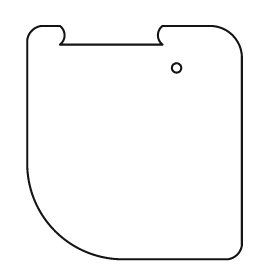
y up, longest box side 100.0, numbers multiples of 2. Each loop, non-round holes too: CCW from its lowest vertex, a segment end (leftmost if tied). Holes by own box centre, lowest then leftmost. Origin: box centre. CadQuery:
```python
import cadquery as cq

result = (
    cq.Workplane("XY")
    .moveTo(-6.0, -50.0)
    .lineTo(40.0, -50.0)
    .threePointArc((44.0, -48.0), (46.0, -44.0))
    .lineTo(46.0, 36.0)
    .threePointArc((42.0, 46.0), (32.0, 50.0))
    .lineTo(12.0, 50.0)
    .threePointArc((10.0, 46.0), (12.0, 42.0))
    .lineTo(-32.0, 42.0)
    .threePointArc((-30.0, 46.0), (-32.0, 50.0))
    .lineTo(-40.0, 50.0)
    .threePointArc((-44.0, 48.0), (-46.0, 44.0))
    .lineTo(-46.0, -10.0)
    .threePointArc((-34.0, -38.0), (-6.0, -50.0))
    .close()
    .moveTo(18.0, 32.0)
    .circle(2.0)
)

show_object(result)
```